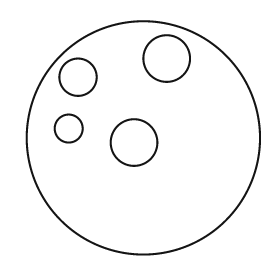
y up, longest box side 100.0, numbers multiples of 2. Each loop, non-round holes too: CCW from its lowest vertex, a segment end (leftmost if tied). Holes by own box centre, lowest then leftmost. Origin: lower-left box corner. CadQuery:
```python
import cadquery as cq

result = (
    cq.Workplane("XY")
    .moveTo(50.0, 50.0)
    .circle(50.0)
    .moveTo(46.0, 48.0)
    .circle(10.0)
    .moveTo(18.0, 54.0)
    .circle(6.0)
    .moveTo(22.0, 76.0)
    .circle(8.0)
    .moveTo(60.0, 84.0)
    .circle(10.0)
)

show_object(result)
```